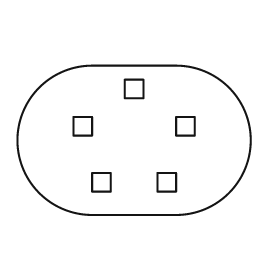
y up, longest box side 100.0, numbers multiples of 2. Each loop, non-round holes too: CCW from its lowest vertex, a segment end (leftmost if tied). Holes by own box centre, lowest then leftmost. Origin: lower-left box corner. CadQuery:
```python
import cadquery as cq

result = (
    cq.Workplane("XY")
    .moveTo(32.0, 0.0)
    .lineTo(68.0, 0.0)
    .threePointArc((100.0, 32.0), (68.0, 64.0))
    .lineTo(32.0, 64.0)
    .threePointArc((0.0, 32.0), (32.0, 0.0))
    .close()
    .moveTo(32.0, 10.0)
    .lineTo(40.0, 10.0)
    .lineTo(40.0, 18.0)
    .lineTo(32.0, 18.0)
    .close()
    .moveTo(60.0, 10.0)
    .lineTo(68.0, 10.0)
    .lineTo(68.0, 18.0)
    .lineTo(60.0, 18.0)
    .close()
    .moveTo(24.0, 34.0)
    .lineTo(32.0, 34.0)
    .lineTo(32.0, 42.0)
    .lineTo(24.0, 42.0)
    .close()
    .moveTo(68.0, 34.0)
    .lineTo(76.0, 34.0)
    .lineTo(76.0, 42.0)
    .lineTo(68.0, 42.0)
    .close()
    .moveTo(46.0, 50.0)
    .lineTo(54.0, 50.0)
    .lineTo(54.0, 58.0)
    .lineTo(46.0, 58.0)
    .close()
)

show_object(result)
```